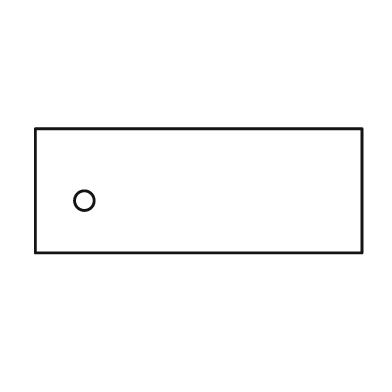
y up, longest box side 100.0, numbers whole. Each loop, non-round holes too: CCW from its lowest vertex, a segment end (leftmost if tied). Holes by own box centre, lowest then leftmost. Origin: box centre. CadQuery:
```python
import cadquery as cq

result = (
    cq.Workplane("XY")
    .moveTo(-50.0, -19.0)
    .lineTo(50.0, -19.0)
    .lineTo(50.0, 19.0)
    .lineTo(-50.0, 19.0)
    .close()
    .moveTo(-35.0, -3.0)
    .circle(3.0)
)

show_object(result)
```